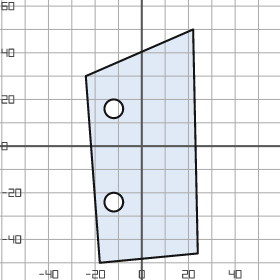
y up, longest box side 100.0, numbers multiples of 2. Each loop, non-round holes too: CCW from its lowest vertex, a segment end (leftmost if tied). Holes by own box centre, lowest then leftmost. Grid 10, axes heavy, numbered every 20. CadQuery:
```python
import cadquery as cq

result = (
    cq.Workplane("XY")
    .moveTo(-18.0, -50.0)
    .lineTo(24.0, -46.0)
    .lineTo(22.0, 50.0)
    .lineTo(-24.0, 30.0)
    .close()
    .moveTo(-12.0, -24.0)
    .circle(4.0)
    .moveTo(-12.0, 16.0)
    .circle(4.0)
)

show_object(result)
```